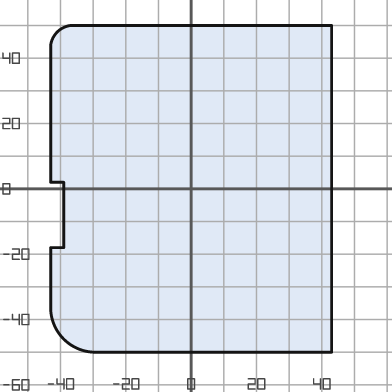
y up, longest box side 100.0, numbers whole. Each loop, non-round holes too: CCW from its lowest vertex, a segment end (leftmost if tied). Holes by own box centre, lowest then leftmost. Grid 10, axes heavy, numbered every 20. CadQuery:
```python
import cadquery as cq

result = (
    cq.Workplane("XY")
    .moveTo(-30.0, -50.0)
    .lineTo(43.0, -50.0)
    .lineTo(43.0, 50.0)
    .lineTo(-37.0, 50.0)
    .threePointArc((-41.0, 48.0), (-43.0, 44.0))
    .lineTo(-43.0, 2.0)
    .lineTo(-39.0, 2.0)
    .lineTo(-39.0, -18.0)
    .lineTo(-43.0, -18.0)
    .lineTo(-43.0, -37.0)
    .threePointArc((-39.0, -46.0), (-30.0, -50.0))
    .close()
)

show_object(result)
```